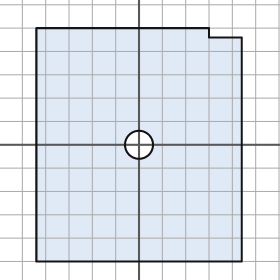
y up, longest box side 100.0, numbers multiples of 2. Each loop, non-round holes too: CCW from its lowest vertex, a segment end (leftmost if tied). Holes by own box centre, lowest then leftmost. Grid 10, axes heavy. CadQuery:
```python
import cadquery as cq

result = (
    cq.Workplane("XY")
    .moveTo(-44.0, -50.0)
    .lineTo(44.0, -50.0)
    .lineTo(44.0, 46.0)
    .lineTo(30.0, 46.0)
    .lineTo(30.0, 50.0)
    .lineTo(-44.0, 50.0)
    .close()
    .moveTo(0.0, 0.0)
    .circle(6.0)
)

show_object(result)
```